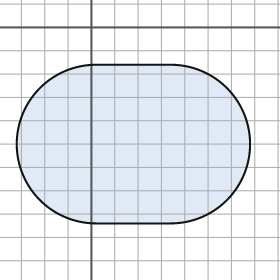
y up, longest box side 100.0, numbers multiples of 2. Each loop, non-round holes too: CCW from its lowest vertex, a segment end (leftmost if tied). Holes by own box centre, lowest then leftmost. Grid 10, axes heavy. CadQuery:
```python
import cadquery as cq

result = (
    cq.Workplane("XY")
    .moveTo(2.0, -84.0)
    .lineTo(34.0, -84.0)
    .threePointArc((68.0, -50.0), (34.0, -16.0))
    .lineTo(2.0, -16.0)
    .threePointArc((-32.0, -50.0), (2.0, -84.0))
    .close()
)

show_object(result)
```